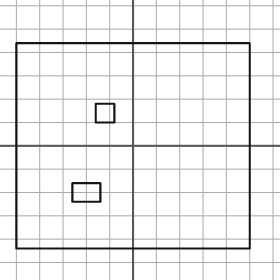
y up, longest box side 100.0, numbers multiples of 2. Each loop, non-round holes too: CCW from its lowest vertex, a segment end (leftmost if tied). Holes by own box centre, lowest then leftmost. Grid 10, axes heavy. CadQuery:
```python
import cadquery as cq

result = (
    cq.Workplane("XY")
    .moveTo(-50.0, -44.0)
    .lineTo(50.0, -44.0)
    .lineTo(50.0, 44.0)
    .lineTo(-50.0, 44.0)
    .close()
    .moveTo(-26.0, -24.0)
    .lineTo(-14.0, -24.0)
    .lineTo(-14.0, -16.0)
    .lineTo(-26.0, -16.0)
    .close()
    .moveTo(-16.0, 10.0)
    .lineTo(-8.0, 10.0)
    .lineTo(-8.0, 18.0)
    .lineTo(-16.0, 18.0)
    .close()
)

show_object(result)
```